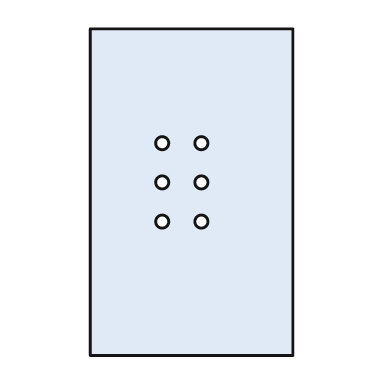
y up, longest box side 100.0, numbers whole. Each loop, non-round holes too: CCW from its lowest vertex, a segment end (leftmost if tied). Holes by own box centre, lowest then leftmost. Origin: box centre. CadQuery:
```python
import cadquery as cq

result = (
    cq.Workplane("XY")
    .moveTo(-31.0, -50.0)
    .lineTo(31.0, -50.0)
    .lineTo(31.0, 50.0)
    .lineTo(-31.0, 50.0)
    .close()
    .moveTo(-9.0, -9.0)
    .circle(2.0)
    .moveTo(3.0, -9.0)
    .circle(2.0)
    .moveTo(-9.0, 3.0)
    .circle(2.0)
    .moveTo(3.0, 3.0)
    .circle(2.0)
    .moveTo(-9.0, 15.0)
    .circle(2.0)
    .moveTo(3.0, 15.0)
    .circle(2.0)
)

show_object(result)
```